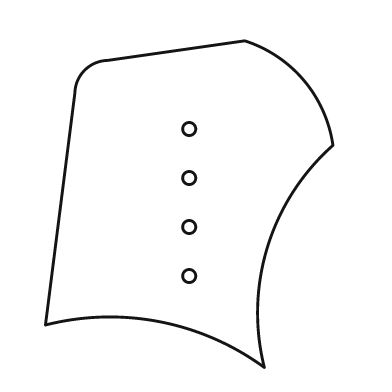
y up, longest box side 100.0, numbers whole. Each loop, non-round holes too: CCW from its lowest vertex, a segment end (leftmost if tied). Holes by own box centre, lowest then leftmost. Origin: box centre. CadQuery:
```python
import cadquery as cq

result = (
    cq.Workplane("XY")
    .moveTo(23.0, -50.0)
    .threePointArc((24.0, -13.0), (44.0, 18.0))
    .threePointArc((35.0, 38.0), (17.0, 50.0))
    .lineTo(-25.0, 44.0)
    .threePointArc((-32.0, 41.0), (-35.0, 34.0))
    .lineTo(-44.0, -37.0)
    .threePointArc((-9.0, -36.0), (23.0, -50.0))
    .close()
    .moveTo(0.0, -22.0)
    .circle(2.0)
    .moveTo(0.0, -7.0)
    .circle(2.0)
    .moveTo(0.0, 8.0)
    .circle(2.0)
    .moveTo(0.0, 23.0)
    .circle(2.0)
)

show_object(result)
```